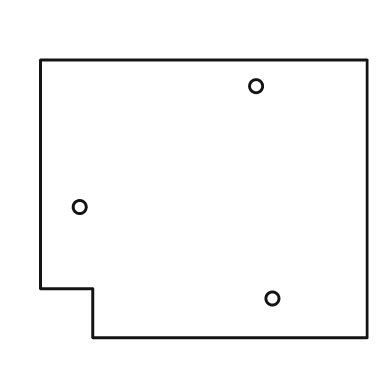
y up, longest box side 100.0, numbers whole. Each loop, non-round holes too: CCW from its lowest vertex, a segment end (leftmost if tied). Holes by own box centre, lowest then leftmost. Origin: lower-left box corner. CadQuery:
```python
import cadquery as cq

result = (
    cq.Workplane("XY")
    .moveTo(16.0, 0.0)
    .lineTo(100.0, 0.0)
    .lineTo(100.0, 85.0)
    .lineTo(0.0, 85.0)
    .lineTo(0.0, 15.0)
    .lineTo(16.0, 15.0)
    .close()
    .moveTo(71.0, 12.0)
    .circle(2.0)
    .moveTo(12.0, 40.0)
    .circle(2.0)
    .moveTo(66.0, 77.0)
    .circle(2.0)
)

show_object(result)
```